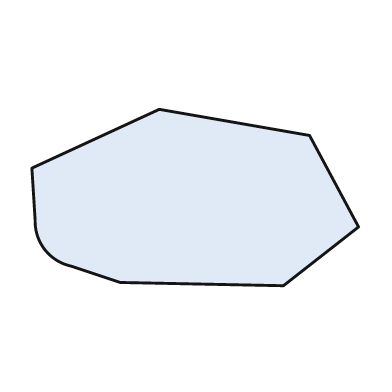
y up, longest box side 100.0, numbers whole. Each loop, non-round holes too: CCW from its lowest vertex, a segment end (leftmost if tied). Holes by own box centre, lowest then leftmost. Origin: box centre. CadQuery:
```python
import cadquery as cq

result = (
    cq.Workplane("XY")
    .moveTo(27.0, -27.0)
    .lineTo(50.0, -9.0)
    .lineTo(35.0, 19.0)
    .lineTo(-11.0, 27.0)
    .lineTo(-50.0, 9.0)
    .lineTo(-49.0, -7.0)
    .threePointArc((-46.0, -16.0), (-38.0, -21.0))
    .lineTo(-23.0, -26.0)
    .close()
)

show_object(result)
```